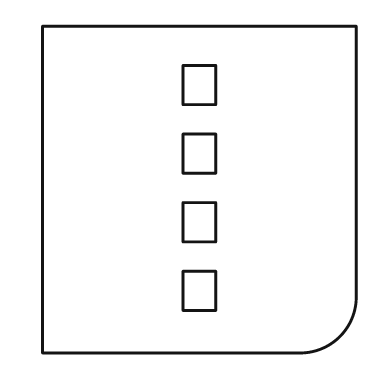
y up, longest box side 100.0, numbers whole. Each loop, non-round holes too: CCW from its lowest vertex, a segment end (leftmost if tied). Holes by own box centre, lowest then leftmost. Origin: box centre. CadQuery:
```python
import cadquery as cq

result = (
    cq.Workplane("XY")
    .moveTo(-48.0, -50.0)
    .lineTo(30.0, -50.0)
    .threePointArc((43.0, -45.0), (48.0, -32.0))
    .lineTo(48.0, 50.0)
    .lineTo(-48.0, 50.0)
    .close()
    .moveTo(-5.0, -37.0)
    .lineTo(5.0, -37.0)
    .lineTo(5.0, -25.0)
    .lineTo(-5.0, -25.0)
    .close()
    .moveTo(-5.0, -16.0)
    .lineTo(5.0, -16.0)
    .lineTo(5.0, -4.0)
    .lineTo(-5.0, -4.0)
    .close()
    .moveTo(-5.0, 5.0)
    .lineTo(5.0, 5.0)
    .lineTo(5.0, 17.0)
    .lineTo(-5.0, 17.0)
    .close()
    .moveTo(-5.0, 26.0)
    .lineTo(5.0, 26.0)
    .lineTo(5.0, 38.0)
    .lineTo(-5.0, 38.0)
    .close()
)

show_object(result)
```